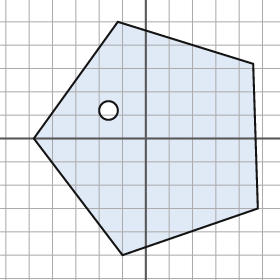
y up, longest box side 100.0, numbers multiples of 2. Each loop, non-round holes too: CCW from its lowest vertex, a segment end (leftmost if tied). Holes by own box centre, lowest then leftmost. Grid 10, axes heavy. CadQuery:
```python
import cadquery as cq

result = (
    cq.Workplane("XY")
    .moveTo(-10.0, -50.0)
    .lineTo(48.0, -30.0)
    .lineTo(46.0, 32.0)
    .lineTo(-12.0, 50.0)
    .lineTo(-48.0, 0.0)
    .close()
    .moveTo(-16.0, 12.0)
    .circle(4.0)
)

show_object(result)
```